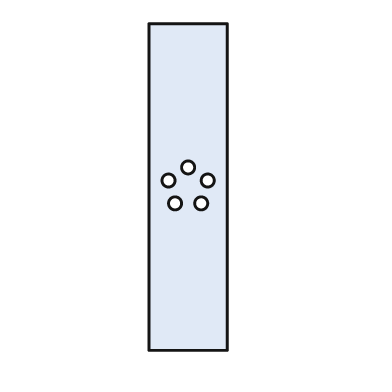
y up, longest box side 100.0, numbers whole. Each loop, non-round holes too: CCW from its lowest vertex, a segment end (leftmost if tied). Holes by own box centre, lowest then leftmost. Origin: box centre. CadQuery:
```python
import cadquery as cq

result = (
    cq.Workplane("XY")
    .moveTo(-12.0, -50.0)
    .lineTo(12.0, -50.0)
    .lineTo(12.0, 50.0)
    .lineTo(-12.0, 50.0)
    .close()
    .moveTo(-4.0, -5.0)
    .circle(2.0)
    .moveTo(4.0, -5.0)
    .circle(2.0)
    .moveTo(-6.0, 2.0)
    .circle(2.0)
    .moveTo(6.0, 2.0)
    .circle(2.0)
    .moveTo(0.0, 6.0)
    .circle(2.0)
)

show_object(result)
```